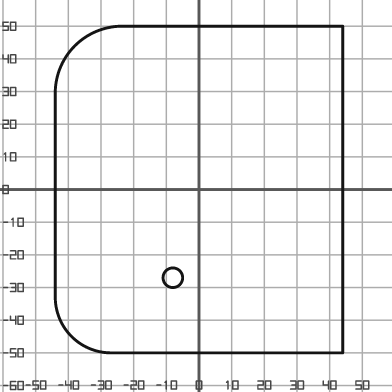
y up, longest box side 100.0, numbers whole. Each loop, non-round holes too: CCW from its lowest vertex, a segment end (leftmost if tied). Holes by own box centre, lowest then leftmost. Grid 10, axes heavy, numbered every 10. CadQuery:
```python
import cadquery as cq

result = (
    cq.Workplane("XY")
    .moveTo(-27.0, -50.0)
    .lineTo(44.0, -50.0)
    .lineTo(44.0, 50.0)
    .lineTo(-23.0, 50.0)
    .threePointArc((-38.0, 44.0), (-44.0, 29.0))
    .lineTo(-44.0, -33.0)
    .threePointArc((-39.0, -45.0), (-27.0, -50.0))
    .close()
    .moveTo(-8.0, -27.0)
    .circle(3.0)
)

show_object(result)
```